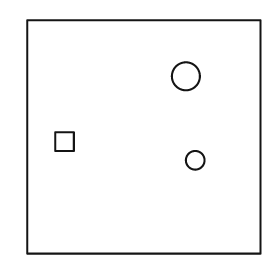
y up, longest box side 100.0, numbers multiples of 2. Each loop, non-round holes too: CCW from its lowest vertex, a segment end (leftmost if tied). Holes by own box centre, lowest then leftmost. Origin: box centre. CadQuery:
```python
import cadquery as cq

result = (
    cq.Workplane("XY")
    .moveTo(-50.0, -50.0)
    .lineTo(50.0, -50.0)
    .lineTo(50.0, 50.0)
    .lineTo(-50.0, 50.0)
    .close()
    .moveTo(22.0, -10.0)
    .circle(4.0)
    .moveTo(-38.0, -6.0)
    .lineTo(-30.0, -6.0)
    .lineTo(-30.0, 2.0)
    .lineTo(-38.0, 2.0)
    .close()
    .moveTo(18.0, 26.0)
    .circle(6.0)
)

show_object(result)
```